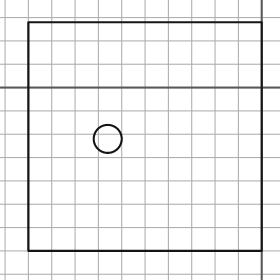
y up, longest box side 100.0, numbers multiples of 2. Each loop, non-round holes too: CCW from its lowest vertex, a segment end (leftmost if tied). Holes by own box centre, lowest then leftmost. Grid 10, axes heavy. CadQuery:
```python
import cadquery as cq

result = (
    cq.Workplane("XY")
    .moveTo(-100.0, -70.0)
    .lineTo(0.0, -70.0)
    .lineTo(0.0, 28.0)
    .lineTo(-100.0, 28.0)
    .close()
    .moveTo(-66.0, -22.0)
    .circle(6.0)
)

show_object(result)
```